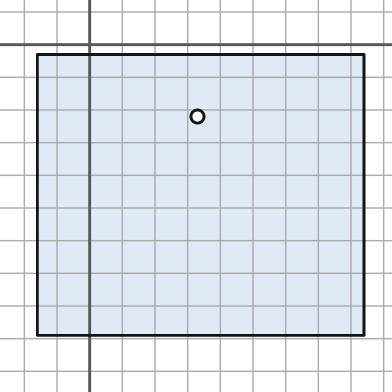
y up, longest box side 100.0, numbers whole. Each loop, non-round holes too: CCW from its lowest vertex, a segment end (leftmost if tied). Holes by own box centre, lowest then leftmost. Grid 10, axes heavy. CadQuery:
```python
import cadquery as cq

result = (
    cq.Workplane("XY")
    .moveTo(-16.0, -89.0)
    .lineTo(84.0, -89.0)
    .lineTo(84.0, -3.0)
    .lineTo(-16.0, -3.0)
    .close()
    .moveTo(33.0, -22.0)
    .circle(2.0)
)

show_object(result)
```